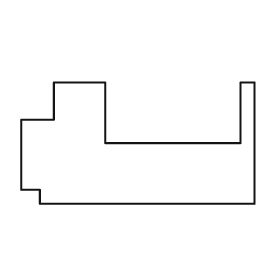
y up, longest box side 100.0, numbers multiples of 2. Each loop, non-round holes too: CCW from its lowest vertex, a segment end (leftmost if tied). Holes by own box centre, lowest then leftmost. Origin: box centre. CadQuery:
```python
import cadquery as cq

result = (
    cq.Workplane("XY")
    .moveTo(-42.0, -26.0)
    .lineTo(50.0, -26.0)
    .lineTo(50.0, 26.0)
    .lineTo(44.0, 26.0)
    .lineTo(44.0, 0.0)
    .lineTo(-14.0, 0.0)
    .lineTo(-14.0, 26.0)
    .lineTo(-36.0, 26.0)
    .lineTo(-36.0, 10.0)
    .lineTo(-50.0, 10.0)
    .lineTo(-50.0, -20.0)
    .lineTo(-42.0, -20.0)
    .close()
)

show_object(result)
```